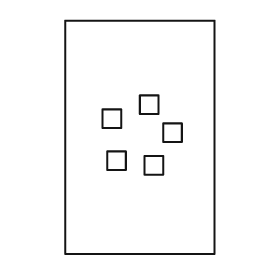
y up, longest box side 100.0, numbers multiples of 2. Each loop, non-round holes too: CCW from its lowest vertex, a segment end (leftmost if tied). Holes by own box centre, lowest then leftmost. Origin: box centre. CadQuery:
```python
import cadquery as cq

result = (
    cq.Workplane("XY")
    .moveTo(-32.0, -50.0)
    .lineTo(32.0, -50.0)
    .lineTo(32.0, 50.0)
    .lineTo(-32.0, 50.0)
    .close()
    .moveTo(2.0, -16.0)
    .lineTo(10.0, -16.0)
    .lineTo(10.0, -8.0)
    .lineTo(2.0, -8.0)
    .close()
    .moveTo(-14.0, -14.0)
    .lineTo(-6.0, -14.0)
    .lineTo(-6.0, -6.0)
    .lineTo(-14.0, -6.0)
    .close()
    .moveTo(10.0, -2.0)
    .lineTo(18.0, -2.0)
    .lineTo(18.0, 6.0)
    .lineTo(10.0, 6.0)
    .close()
    .moveTo(-16.0, 4.0)
    .lineTo(-8.0, 4.0)
    .lineTo(-8.0, 12.0)
    .lineTo(-16.0, 12.0)
    .close()
    .moveTo(0.0, 10.0)
    .lineTo(8.0, 10.0)
    .lineTo(8.0, 18.0)
    .lineTo(0.0, 18.0)
    .close()
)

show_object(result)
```